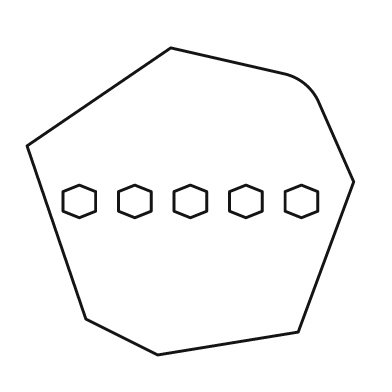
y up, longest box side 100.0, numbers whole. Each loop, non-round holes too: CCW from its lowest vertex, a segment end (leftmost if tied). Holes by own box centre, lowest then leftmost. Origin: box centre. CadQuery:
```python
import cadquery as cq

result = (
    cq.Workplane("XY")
    .moveTo(-10.0, -47.0)
    .lineTo(33.0, -40.0)
    .lineTo(50.0, 6.0)
    .lineTo(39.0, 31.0)
    .threePointArc((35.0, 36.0), (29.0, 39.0))
    .lineTo(-6.0, 47.0)
    .lineTo(-50.0, 17.0)
    .lineTo(-32.0, -36.0)
    .close()
    .moveTo(-34.0, -5.0)
    .lineTo(-29.0, -3.0)
    .lineTo(-29.0, 3.0)
    .lineTo(-34.0, 5.0)
    .lineTo(-39.0, 3.0)
    .lineTo(-39.0, -3.0)
    .close()
    .moveTo(-17.0, -5.0)
    .lineTo(-12.0, -3.0)
    .lineTo(-12.0, 3.0)
    .lineTo(-17.0, 5.0)
    .lineTo(-22.0, 3.0)
    .lineTo(-22.0, -3.0)
    .close()
    .moveTo(0.0, -5.0)
    .lineTo(5.0, -3.0)
    .lineTo(5.0, 3.0)
    .lineTo(0.0, 5.0)
    .lineTo(-5.0, 3.0)
    .lineTo(-5.0, -3.0)
    .close()
    .moveTo(17.0, -5.0)
    .lineTo(22.0, -3.0)
    .lineTo(22.0, 3.0)
    .lineTo(17.0, 5.0)
    .lineTo(12.0, 3.0)
    .lineTo(12.0, -3.0)
    .close()
    .moveTo(34.0, -5.0)
    .lineTo(39.0, -3.0)
    .lineTo(39.0, 3.0)
    .lineTo(34.0, 5.0)
    .lineTo(29.0, 3.0)
    .lineTo(29.0, -3.0)
    .close()
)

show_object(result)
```